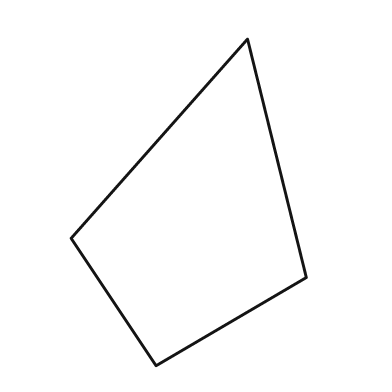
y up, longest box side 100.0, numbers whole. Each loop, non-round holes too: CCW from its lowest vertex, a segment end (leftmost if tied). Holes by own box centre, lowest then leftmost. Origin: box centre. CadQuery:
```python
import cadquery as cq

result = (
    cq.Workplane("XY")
    .moveTo(-10.0, -50.0)
    .lineTo(36.0, -23.0)
    .lineTo(18.0, 50.0)
    .lineTo(-36.0, -11.0)
    .close()
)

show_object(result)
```